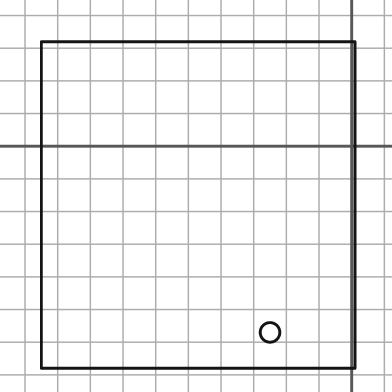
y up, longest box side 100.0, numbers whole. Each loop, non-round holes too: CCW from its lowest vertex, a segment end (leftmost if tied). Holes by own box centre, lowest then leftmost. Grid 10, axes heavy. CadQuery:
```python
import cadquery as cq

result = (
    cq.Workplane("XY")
    .moveTo(-95.0, -68.0)
    .lineTo(1.0, -68.0)
    .lineTo(1.0, 32.0)
    .lineTo(-95.0, 32.0)
    .close()
    .moveTo(-25.0, -57.0)
    .circle(3.0)
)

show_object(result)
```